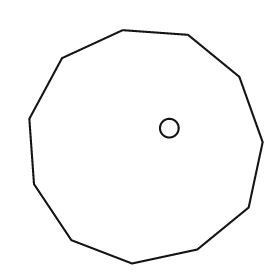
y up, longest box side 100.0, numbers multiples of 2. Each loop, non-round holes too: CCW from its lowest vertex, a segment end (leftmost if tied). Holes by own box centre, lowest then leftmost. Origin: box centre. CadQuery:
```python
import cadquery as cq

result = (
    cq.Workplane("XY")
    .moveTo(-6.0, -50.0)
    .lineTo(22.0, -44.0)
    .lineTo(44.0, -26.0)
    .lineTo(50.0, 2.0)
    .lineTo(40.0, 30.0)
    .lineTo(18.0, 48.0)
    .lineTo(-10.0, 50.0)
    .lineTo(-36.0, 38.0)
    .lineTo(-50.0, 12.0)
    .lineTo(-48.0, -16.0)
    .lineTo(-32.0, -40.0)
    .close()
    .moveTo(10.0, 8.0)
    .circle(4.0)
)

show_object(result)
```